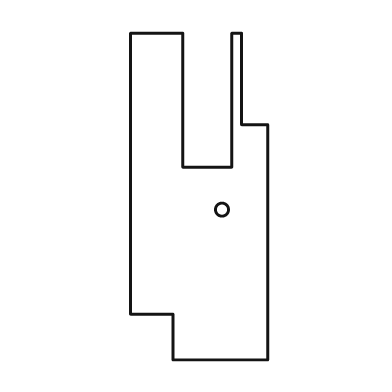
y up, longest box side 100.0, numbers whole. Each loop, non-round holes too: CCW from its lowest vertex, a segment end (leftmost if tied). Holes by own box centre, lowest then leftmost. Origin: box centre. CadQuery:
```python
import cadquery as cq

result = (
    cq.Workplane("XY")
    .moveTo(-8.0, -50.0)
    .lineTo(21.0, -50.0)
    .lineTo(21.0, 22.0)
    .lineTo(13.0, 22.0)
    .lineTo(13.0, 50.0)
    .lineTo(10.0, 50.0)
    .lineTo(10.0, 9.0)
    .lineTo(-5.0, 9.0)
    .lineTo(-5.0, 50.0)
    .lineTo(-21.0, 50.0)
    .lineTo(-21.0, -36.0)
    .lineTo(-8.0, -36.0)
    .close()
    .moveTo(7.0, -4.0)
    .circle(2.0)
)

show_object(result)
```